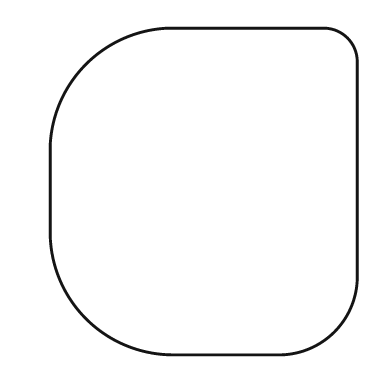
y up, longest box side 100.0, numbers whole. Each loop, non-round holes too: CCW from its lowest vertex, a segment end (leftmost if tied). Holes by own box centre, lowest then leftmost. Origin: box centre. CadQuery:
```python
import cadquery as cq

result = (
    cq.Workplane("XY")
    .moveTo(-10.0, -50.0)
    .lineTo(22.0, -50.0)
    .threePointArc((40.0, -43.0), (47.0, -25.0))
    .lineTo(47.0, 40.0)
    .threePointArc((44.0, 47.0), (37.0, 50.0))
    .lineTo(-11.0, 50.0)
    .threePointArc((-36.0, 39.0), (-47.0, 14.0))
    .lineTo(-47.0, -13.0)
    .threePointArc((-36.0, -39.0), (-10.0, -50.0))
    .close()
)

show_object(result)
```